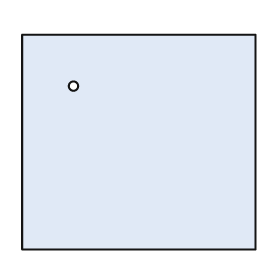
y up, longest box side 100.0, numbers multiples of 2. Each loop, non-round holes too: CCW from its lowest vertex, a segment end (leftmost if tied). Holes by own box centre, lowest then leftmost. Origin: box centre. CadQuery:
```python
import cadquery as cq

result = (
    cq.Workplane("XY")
    .moveTo(-50.0, -46.0)
    .lineTo(50.0, -46.0)
    .lineTo(50.0, 46.0)
    .lineTo(-50.0, 46.0)
    .close()
    .moveTo(-28.0, 24.0)
    .circle(2.0)
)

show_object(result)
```